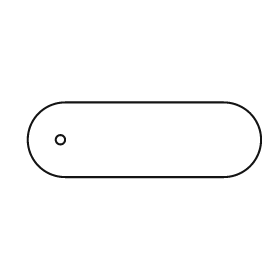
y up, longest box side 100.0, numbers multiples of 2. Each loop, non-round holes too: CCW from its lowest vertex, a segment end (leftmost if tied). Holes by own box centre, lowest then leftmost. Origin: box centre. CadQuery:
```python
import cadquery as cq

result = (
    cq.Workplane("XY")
    .moveTo(-34.0, -16.0)
    .lineTo(34.0, -16.0)
    .threePointArc((50.0, 0.0), (34.0, 16.0))
    .lineTo(-34.0, 16.0)
    .threePointArc((-50.0, 0.0), (-34.0, -16.0))
    .close()
    .moveTo(-36.0, 0.0)
    .circle(2.0)
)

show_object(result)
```